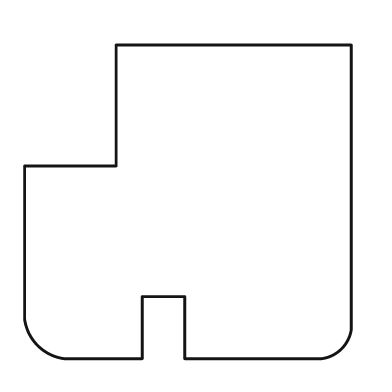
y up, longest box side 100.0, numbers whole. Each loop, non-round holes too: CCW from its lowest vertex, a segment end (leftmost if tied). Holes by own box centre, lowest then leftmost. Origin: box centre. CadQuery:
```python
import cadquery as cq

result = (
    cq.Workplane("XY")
    .moveTo(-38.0, -48.0)
    .lineTo(-14.0, -48.0)
    .lineTo(-14.0, -29.0)
    .lineTo(-1.0, -29.0)
    .lineTo(-1.0, -48.0)
    .lineTo(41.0, -48.0)
    .threePointArc((47.0, -45.0), (50.0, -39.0))
    .lineTo(50.0, 48.0)
    .lineTo(-22.0, 48.0)
    .lineTo(-22.0, 11.0)
    .lineTo(-50.0, 11.0)
    .lineTo(-50.0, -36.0)
    .threePointArc((-46.0, -44.0), (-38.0, -48.0))
    .close()
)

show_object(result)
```